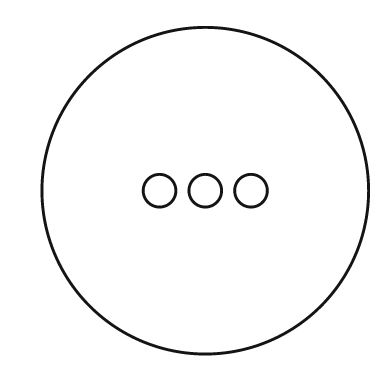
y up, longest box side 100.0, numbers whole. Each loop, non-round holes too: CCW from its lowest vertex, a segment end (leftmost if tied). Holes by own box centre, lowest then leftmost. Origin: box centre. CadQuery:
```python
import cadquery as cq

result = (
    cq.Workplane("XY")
    .moveTo(0.0, 0.0)
    .circle(50.0)
    .moveTo(-14.0, 0.0)
    .circle(5.0)
    .moveTo(0.0, 0.0)
    .circle(5.0)
    .moveTo(14.0, 0.0)
    .circle(5.0)
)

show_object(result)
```